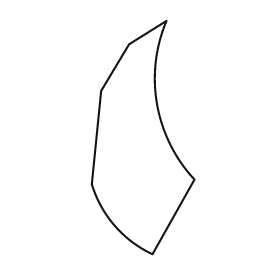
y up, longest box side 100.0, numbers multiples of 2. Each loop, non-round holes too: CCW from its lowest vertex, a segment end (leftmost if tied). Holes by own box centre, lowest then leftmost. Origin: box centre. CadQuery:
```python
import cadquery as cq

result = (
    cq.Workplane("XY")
    .moveTo(4.0, -50.0)
    .lineTo(22.0, -18.0)
    .threePointArc((6.0, 14.0), (10.0, 50.0))
    .lineTo(-6.0, 40.0)
    .lineTo(-18.0, 20.0)
    .lineTo(-22.0, -20.0)
    .threePointArc((-12.0, -38.0), (4.0, -50.0))
    .close()
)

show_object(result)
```